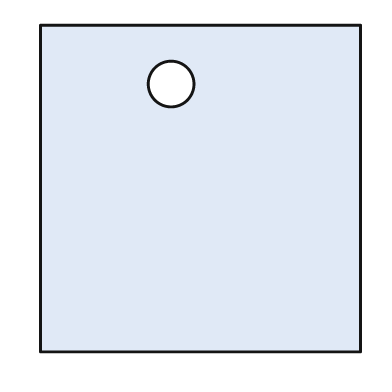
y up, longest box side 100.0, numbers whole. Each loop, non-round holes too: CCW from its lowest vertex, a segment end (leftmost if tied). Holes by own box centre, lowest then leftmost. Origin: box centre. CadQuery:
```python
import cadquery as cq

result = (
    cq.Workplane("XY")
    .moveTo(-49.0, -50.0)
    .lineTo(49.0, -50.0)
    .lineTo(49.0, 50.0)
    .lineTo(-49.0, 50.0)
    .close()
    .moveTo(-9.0, 32.0)
    .circle(7.0)
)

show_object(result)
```